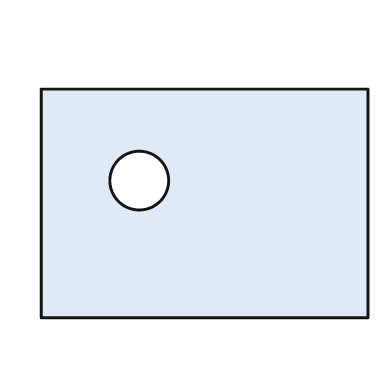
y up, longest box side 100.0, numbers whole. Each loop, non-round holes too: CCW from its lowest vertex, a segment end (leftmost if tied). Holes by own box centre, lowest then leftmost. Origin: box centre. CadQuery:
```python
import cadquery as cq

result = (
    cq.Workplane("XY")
    .moveTo(-50.0, -35.0)
    .lineTo(50.0, -35.0)
    .lineTo(50.0, 35.0)
    .lineTo(-50.0, 35.0)
    .close()
    .moveTo(-20.0, 7.0)
    .circle(9.0)
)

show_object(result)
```